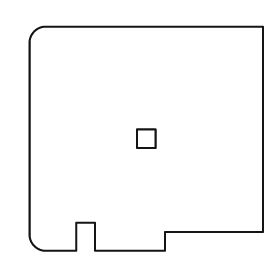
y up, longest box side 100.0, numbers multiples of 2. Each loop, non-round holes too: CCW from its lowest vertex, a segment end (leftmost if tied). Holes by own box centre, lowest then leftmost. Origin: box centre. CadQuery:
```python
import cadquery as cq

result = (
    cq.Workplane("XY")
    .moveTo(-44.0, -48.0)
    .lineTo(-30.0, -48.0)
    .lineTo(-30.0, -36.0)
    .lineTo(-22.0, -36.0)
    .lineTo(-22.0, -48.0)
    .lineTo(8.0, -48.0)
    .lineTo(8.0, -40.0)
    .lineTo(50.0, -40.0)
    .lineTo(50.0, 48.0)
    .lineTo(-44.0, 48.0)
    .threePointArc((-48.0, 46.0), (-50.0, 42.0))
    .lineTo(-50.0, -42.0)
    .threePointArc((-48.0, -46.0), (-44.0, -48.0))
    .close()
    .moveTo(-4.0, -4.0)
    .lineTo(4.0, -4.0)
    .lineTo(4.0, 4.0)
    .lineTo(-4.0, 4.0)
    .close()
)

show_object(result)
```